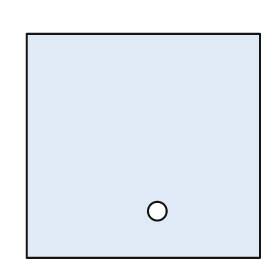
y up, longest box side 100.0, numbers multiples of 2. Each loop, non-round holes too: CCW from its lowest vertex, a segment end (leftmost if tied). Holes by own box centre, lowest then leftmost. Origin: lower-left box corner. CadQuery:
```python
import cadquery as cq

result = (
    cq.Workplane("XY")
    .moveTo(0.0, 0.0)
    .lineTo(100.0, 0.0)
    .lineTo(100.0, 96.0)
    .lineTo(0.0, 96.0)
    .close()
    .moveTo(56.0, 20.0)
    .circle(4.0)
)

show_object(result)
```